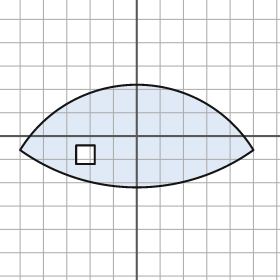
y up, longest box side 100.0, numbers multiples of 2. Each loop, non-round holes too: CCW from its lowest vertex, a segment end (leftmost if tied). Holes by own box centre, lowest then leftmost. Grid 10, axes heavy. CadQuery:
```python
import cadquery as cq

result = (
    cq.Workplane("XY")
    .moveTo(-50.0, -6.0)
    .threePointArc((0.0, -22.0), (50.0, -6.0))
    .threePointArc((0.0, 22.0), (-50.0, -6.0))
    .close()
    .moveTo(-26.0, -12.0)
    .lineTo(-18.0, -12.0)
    .lineTo(-18.0, -4.0)
    .lineTo(-26.0, -4.0)
    .close()
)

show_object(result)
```